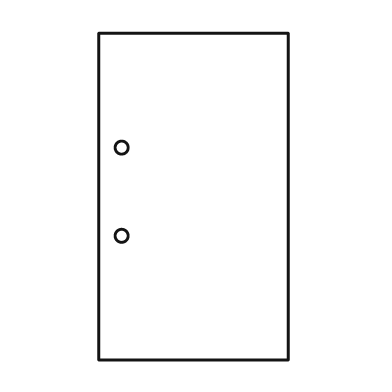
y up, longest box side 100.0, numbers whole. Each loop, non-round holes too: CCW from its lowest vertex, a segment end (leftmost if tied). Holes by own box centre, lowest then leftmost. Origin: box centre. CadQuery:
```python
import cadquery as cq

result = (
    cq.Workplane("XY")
    .moveTo(-29.0, -50.0)
    .lineTo(29.0, -50.0)
    .lineTo(29.0, 50.0)
    .lineTo(-29.0, 50.0)
    .close()
    .moveTo(-22.0, -12.0)
    .circle(2.0)
    .moveTo(-22.0, 15.0)
    .circle(2.0)
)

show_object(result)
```